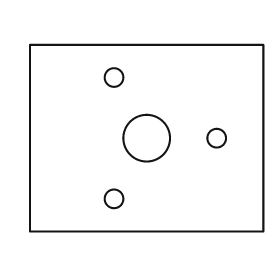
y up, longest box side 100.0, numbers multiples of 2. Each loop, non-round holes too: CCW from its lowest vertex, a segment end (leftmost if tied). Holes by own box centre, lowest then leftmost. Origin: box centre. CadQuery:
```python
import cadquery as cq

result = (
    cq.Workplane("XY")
    .moveTo(-50.0, -40.0)
    .lineTo(50.0, -40.0)
    .lineTo(50.0, 40.0)
    .lineTo(-50.0, 40.0)
    .close()
    .moveTo(-14.0, -26.0)
    .circle(4.0)
    .moveTo(0.0, 0.0)
    .circle(10.0)
    .moveTo(30.0, 0.0)
    .circle(4.0)
    .moveTo(-14.0, 26.0)
    .circle(4.0)
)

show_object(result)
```